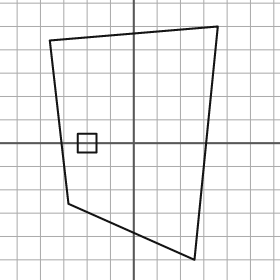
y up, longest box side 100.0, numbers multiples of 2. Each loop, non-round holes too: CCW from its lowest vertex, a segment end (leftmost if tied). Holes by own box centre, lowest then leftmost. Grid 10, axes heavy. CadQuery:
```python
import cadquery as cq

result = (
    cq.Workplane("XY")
    .moveTo(26.0, -50.0)
    .lineTo(36.0, 50.0)
    .lineTo(-36.0, 44.0)
    .lineTo(-28.0, -26.0)
    .close()
    .moveTo(-24.0, -4.0)
    .lineTo(-16.0, -4.0)
    .lineTo(-16.0, 4.0)
    .lineTo(-24.0, 4.0)
    .close()
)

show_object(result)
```